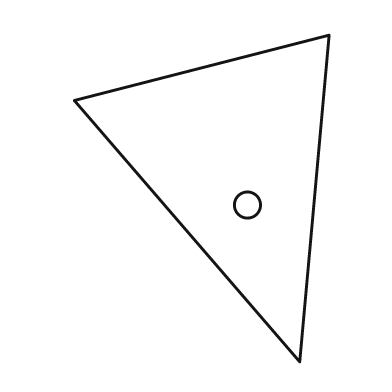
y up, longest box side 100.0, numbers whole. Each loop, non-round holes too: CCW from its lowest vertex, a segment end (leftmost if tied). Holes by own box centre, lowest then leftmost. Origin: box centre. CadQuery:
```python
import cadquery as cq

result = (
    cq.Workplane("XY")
    .moveTo(30.0, -50.0)
    .lineTo(39.0, 50.0)
    .lineTo(-39.0, 30.0)
    .close()
    .moveTo(14.0, -2.0)
    .circle(4.0)
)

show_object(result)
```